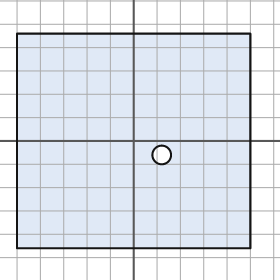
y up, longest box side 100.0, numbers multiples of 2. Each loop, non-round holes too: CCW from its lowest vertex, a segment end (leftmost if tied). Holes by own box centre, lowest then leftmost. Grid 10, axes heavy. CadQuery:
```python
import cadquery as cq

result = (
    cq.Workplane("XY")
    .moveTo(-50.0, -46.0)
    .lineTo(50.0, -46.0)
    .lineTo(50.0, 46.0)
    .lineTo(-50.0, 46.0)
    .close()
    .moveTo(12.0, -6.0)
    .circle(4.0)
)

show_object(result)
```